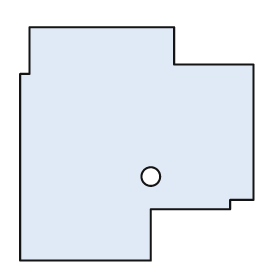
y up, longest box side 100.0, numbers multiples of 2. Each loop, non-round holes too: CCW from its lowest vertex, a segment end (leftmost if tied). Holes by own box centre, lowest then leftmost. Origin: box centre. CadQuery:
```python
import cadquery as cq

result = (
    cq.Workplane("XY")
    .moveTo(-50.0, -50.0)
    .lineTo(6.0, -50.0)
    .lineTo(6.0, -28.0)
    .lineTo(40.0, -28.0)
    .lineTo(40.0, -24.0)
    .lineTo(50.0, -24.0)
    .lineTo(50.0, 34.0)
    .lineTo(16.0, 34.0)
    .lineTo(16.0, 50.0)
    .lineTo(-46.0, 50.0)
    .lineTo(-46.0, 30.0)
    .lineTo(-50.0, 30.0)
    .close()
    .moveTo(6.0, -14.0)
    .circle(4.0)
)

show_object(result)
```